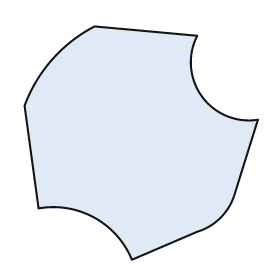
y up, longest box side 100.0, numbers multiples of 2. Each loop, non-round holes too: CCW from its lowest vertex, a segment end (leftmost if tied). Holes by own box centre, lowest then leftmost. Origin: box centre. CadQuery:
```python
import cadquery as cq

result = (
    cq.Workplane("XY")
    .moveTo(-4.0, -50.0)
    .lineTo(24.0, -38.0)
    .threePointArc((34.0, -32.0), (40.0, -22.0))
    .lineTo(50.0, 10.0)
    .threePointArc((26.0, 20.0), (24.0, 46.0))
    .lineTo(-20.0, 50.0)
    .threePointArc((-38.0, 36.0), (-50.0, 16.0))
    .lineTo(-44.0, -28.0)
    .threePointArc((-20.0, -32.0), (-4.0, -50.0))
    .close()
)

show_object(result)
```